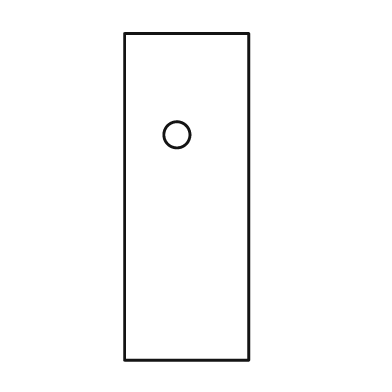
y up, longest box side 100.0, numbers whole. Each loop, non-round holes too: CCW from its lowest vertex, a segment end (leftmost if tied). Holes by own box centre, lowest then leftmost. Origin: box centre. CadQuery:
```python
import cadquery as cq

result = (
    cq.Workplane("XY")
    .moveTo(-19.0, -50.0)
    .lineTo(19.0, -50.0)
    .lineTo(19.0, 50.0)
    .lineTo(-19.0, 50.0)
    .close()
    .moveTo(-3.0, 19.0)
    .circle(4.0)
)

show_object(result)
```